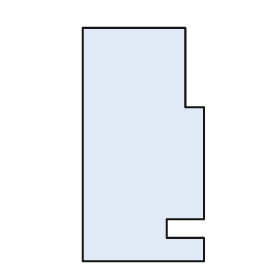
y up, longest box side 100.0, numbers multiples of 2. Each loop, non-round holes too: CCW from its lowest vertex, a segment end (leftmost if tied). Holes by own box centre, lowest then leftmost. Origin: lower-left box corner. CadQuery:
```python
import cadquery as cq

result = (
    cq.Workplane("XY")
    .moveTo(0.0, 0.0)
    .lineTo(52.0, 0.0)
    .lineTo(52.0, 10.0)
    .lineTo(36.0, 10.0)
    .lineTo(36.0, 18.0)
    .lineTo(52.0, 18.0)
    .lineTo(52.0, 66.0)
    .lineTo(44.0, 66.0)
    .lineTo(44.0, 100.0)
    .lineTo(0.0, 100.0)
    .close()
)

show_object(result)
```